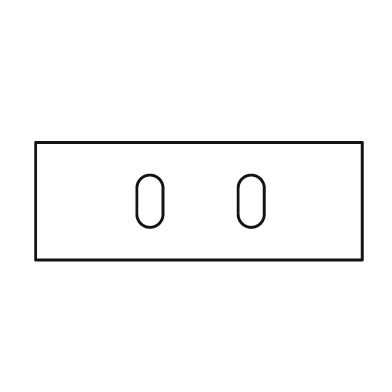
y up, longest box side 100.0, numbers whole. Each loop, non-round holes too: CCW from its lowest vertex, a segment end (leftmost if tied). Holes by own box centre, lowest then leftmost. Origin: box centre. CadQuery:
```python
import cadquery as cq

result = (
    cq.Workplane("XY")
    .moveTo(-50.0, -18.0)
    .lineTo(50.0, -18.0)
    .lineTo(50.0, 18.0)
    .lineTo(-50.0, 18.0)
    .close()
    .moveTo(-19.0, -4.0)
    .threePointArc((-15.0, -8.0), (-11.0, -4.0))
    .lineTo(-11.0, 4.0)
    .threePointArc((-15.0, 8.0), (-19.0, 4.0))
    .close()
    .moveTo(12.0, -4.0)
    .threePointArc((16.0, -8.0), (20.0, -4.0))
    .lineTo(20.0, 4.0)
    .threePointArc((16.0, 8.0), (12.0, 4.0))
    .close()
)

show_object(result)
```